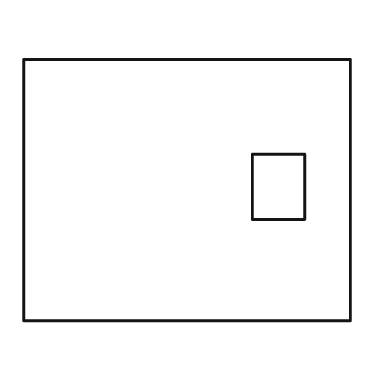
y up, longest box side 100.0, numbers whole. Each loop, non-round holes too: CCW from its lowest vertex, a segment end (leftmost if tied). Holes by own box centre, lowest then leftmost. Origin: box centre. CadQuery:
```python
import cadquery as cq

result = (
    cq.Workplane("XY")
    .moveTo(-50.0, -40.0)
    .lineTo(50.0, -40.0)
    .lineTo(50.0, 40.0)
    .lineTo(-50.0, 40.0)
    .close()
    .moveTo(20.0, -9.0)
    .lineTo(36.0, -9.0)
    .lineTo(36.0, 11.0)
    .lineTo(20.0, 11.0)
    .close()
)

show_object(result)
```